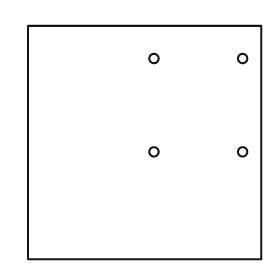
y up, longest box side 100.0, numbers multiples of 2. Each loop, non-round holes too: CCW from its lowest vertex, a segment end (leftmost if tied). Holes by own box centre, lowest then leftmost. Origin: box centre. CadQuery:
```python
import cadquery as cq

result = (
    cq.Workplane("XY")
    .moveTo(-50.0, -50.0)
    .lineTo(50.0, -50.0)
    .lineTo(50.0, 50.0)
    .lineTo(-50.0, 50.0)
    .close()
    .moveTo(4.0, -4.0)
    .circle(2.0)
    .moveTo(42.0, -4.0)
    .circle(2.0)
    .moveTo(4.0, 36.0)
    .circle(2.0)
    .moveTo(42.0, 36.0)
    .circle(2.0)
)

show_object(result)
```